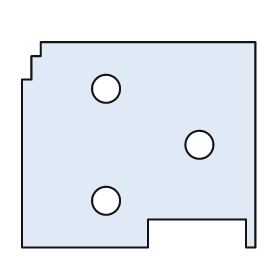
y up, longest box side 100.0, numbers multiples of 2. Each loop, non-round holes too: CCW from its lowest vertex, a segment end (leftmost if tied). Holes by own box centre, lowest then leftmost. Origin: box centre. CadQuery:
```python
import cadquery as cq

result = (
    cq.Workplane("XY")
    .moveTo(-50.0, -44.0)
    .lineTo(4.0, -44.0)
    .lineTo(4.0, -32.0)
    .lineTo(46.0, -32.0)
    .lineTo(46.0, -44.0)
    .lineTo(50.0, -44.0)
    .lineTo(50.0, 44.0)
    .lineTo(-42.0, 44.0)
    .lineTo(-42.0, 38.0)
    .lineTo(-46.0, 38.0)
    .lineTo(-46.0, 28.0)
    .lineTo(-50.0, 28.0)
    .close()
    .moveTo(-14.0, -24.0)
    .circle(6.0)
    .moveTo(26.0, 0.0)
    .circle(6.0)
    .moveTo(-14.0, 24.0)
    .circle(6.0)
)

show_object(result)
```